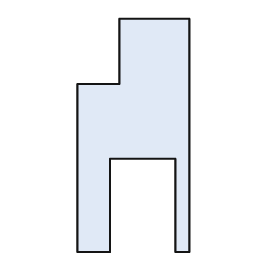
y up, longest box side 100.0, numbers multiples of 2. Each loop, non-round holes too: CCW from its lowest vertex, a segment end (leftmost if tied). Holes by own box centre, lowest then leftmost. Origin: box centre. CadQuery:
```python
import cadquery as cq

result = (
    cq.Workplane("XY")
    .moveTo(-24.0, -50.0)
    .lineTo(-10.0, -50.0)
    .lineTo(-10.0, -10.0)
    .lineTo(18.0, -10.0)
    .lineTo(18.0, -50.0)
    .lineTo(24.0, -50.0)
    .lineTo(24.0, 50.0)
    .lineTo(-6.0, 50.0)
    .lineTo(-6.0, 22.0)
    .lineTo(-24.0, 22.0)
    .close()
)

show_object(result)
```